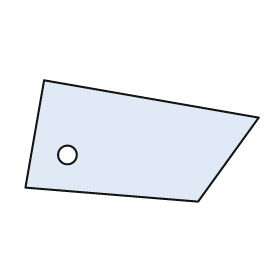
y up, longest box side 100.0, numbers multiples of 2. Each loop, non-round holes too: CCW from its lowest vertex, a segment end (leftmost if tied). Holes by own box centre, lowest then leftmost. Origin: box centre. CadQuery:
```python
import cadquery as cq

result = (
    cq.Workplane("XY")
    .moveTo(24.0, -26.0)
    .lineTo(50.0, 10.0)
    .lineTo(-42.0, 26.0)
    .lineTo(-50.0, -20.0)
    .close()
    .moveTo(-32.0, -6.0)
    .circle(4.0)
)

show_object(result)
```